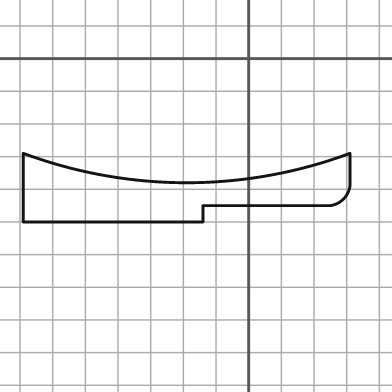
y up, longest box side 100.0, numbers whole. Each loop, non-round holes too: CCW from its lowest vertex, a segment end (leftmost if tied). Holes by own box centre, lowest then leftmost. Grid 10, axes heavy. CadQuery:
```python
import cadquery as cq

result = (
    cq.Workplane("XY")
    .moveTo(-69.0, -50.0)
    .lineTo(-14.0, -50.0)
    .lineTo(-14.0, -45.0)
    .lineTo(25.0, -45.0)
    .threePointArc((29.0, -43.0), (31.0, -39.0))
    .lineTo(31.0, -29.0)
    .threePointArc((-19.0, -38.0), (-69.0, -29.0))
    .close()
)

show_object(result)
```